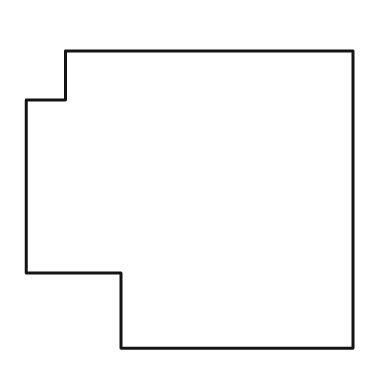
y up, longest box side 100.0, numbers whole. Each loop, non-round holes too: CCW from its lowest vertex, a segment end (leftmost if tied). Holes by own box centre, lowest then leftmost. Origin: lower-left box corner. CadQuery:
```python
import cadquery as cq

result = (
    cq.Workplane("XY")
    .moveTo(29.0, 0.0)
    .lineTo(100.0, 0.0)
    .lineTo(100.0, 91.0)
    .lineTo(12.0, 91.0)
    .lineTo(12.0, 76.0)
    .lineTo(0.0, 76.0)
    .lineTo(0.0, 23.0)
    .lineTo(29.0, 23.0)
    .close()
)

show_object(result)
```